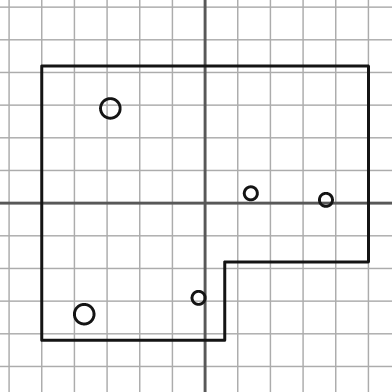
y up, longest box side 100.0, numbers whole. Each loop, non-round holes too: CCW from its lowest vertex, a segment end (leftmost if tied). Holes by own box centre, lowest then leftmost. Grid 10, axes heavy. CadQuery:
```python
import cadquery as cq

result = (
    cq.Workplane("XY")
    .moveTo(-50.0, -42.0)
    .lineTo(6.0, -42.0)
    .lineTo(6.0, -18.0)
    .lineTo(50.0, -18.0)
    .lineTo(50.0, 42.0)
    .lineTo(-50.0, 42.0)
    .close()
    .moveTo(-37.0, -34.0)
    .circle(3.0)
    .moveTo(-2.0, -29.0)
    .circle(2.0)
    .moveTo(37.0, 1.0)
    .circle(2.0)
    .moveTo(14.0, 3.0)
    .circle(2.0)
    .moveTo(-29.0, 29.0)
    .circle(3.0)
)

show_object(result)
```